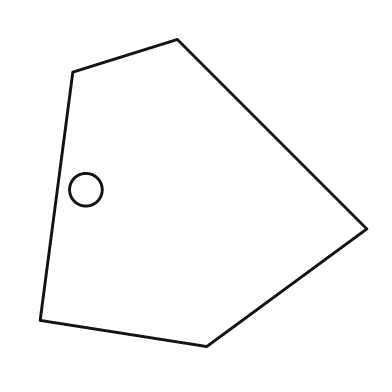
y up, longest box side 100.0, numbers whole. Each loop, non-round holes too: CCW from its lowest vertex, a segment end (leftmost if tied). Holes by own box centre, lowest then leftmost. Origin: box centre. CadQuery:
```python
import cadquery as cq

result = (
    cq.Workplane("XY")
    .moveTo(1.0, -47.0)
    .lineTo(50.0, -11.0)
    .lineTo(-8.0, 47.0)
    .lineTo(-40.0, 37.0)
    .lineTo(-50.0, -39.0)
    .close()
    .moveTo(-36.0, 1.0)
    .circle(5.0)
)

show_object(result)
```